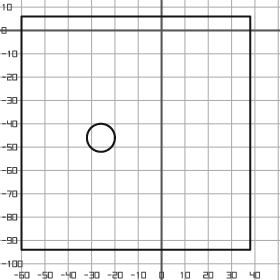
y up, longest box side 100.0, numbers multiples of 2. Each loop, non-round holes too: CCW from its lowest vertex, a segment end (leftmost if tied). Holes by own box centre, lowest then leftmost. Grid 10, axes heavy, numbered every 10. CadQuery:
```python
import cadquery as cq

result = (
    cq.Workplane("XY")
    .moveTo(-60.0, -94.0)
    .lineTo(38.0, -94.0)
    .lineTo(38.0, 6.0)
    .lineTo(-60.0, 6.0)
    .close()
    .moveTo(-26.0, -46.0)
    .circle(6.0)
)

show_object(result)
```